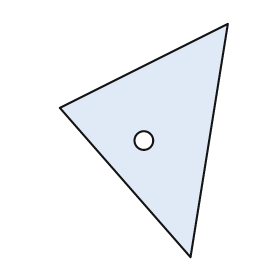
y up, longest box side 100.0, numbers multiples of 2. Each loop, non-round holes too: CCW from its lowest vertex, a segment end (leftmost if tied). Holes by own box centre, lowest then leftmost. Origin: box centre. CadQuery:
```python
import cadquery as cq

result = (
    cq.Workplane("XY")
    .moveTo(20.0, -50.0)
    .lineTo(36.0, 50.0)
    .lineTo(-36.0, 14.0)
    .close()
    .moveTo(0.0, 0.0)
    .circle(4.0)
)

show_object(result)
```